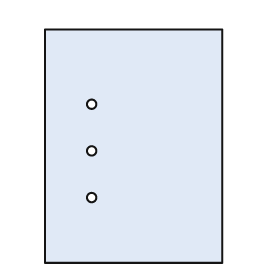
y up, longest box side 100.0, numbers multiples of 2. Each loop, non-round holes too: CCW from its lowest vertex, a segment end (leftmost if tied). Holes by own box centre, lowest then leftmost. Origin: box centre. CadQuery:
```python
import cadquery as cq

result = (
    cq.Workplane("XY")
    .moveTo(-38.0, -50.0)
    .lineTo(38.0, -50.0)
    .lineTo(38.0, 50.0)
    .lineTo(-38.0, 50.0)
    .close()
    .moveTo(-18.0, -22.0)
    .circle(2.0)
    .moveTo(-18.0, -2.0)
    .circle(2.0)
    .moveTo(-18.0, 18.0)
    .circle(2.0)
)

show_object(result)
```